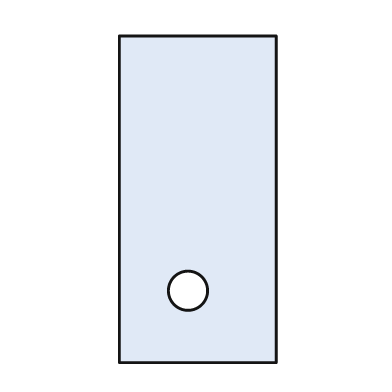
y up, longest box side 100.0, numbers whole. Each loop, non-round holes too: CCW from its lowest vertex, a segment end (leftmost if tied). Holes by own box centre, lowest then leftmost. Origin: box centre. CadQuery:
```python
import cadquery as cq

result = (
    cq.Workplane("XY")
    .moveTo(-24.0, -50.0)
    .lineTo(24.0, -50.0)
    .lineTo(24.0, 50.0)
    .lineTo(-24.0, 50.0)
    .close()
    .moveTo(-3.0, -28.0)
    .circle(6.0)
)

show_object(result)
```